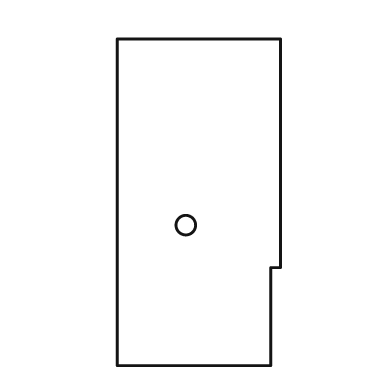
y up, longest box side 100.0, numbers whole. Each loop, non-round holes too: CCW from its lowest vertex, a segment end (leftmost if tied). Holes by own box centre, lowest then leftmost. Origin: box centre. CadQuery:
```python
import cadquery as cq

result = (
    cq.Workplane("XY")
    .moveTo(-25.0, -50.0)
    .lineTo(22.0, -50.0)
    .lineTo(22.0, -20.0)
    .lineTo(25.0, -20.0)
    .lineTo(25.0, 50.0)
    .lineTo(-25.0, 50.0)
    .close()
    .moveTo(-4.0, -7.0)
    .circle(3.0)
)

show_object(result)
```